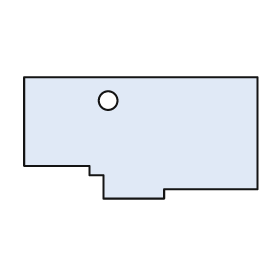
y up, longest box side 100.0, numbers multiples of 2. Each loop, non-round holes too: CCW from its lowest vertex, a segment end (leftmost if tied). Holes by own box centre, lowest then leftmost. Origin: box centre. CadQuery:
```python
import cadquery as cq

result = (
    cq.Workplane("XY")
    .moveTo(-16.0, -26.0)
    .lineTo(10.0, -26.0)
    .lineTo(10.0, -22.0)
    .lineTo(50.0, -22.0)
    .lineTo(50.0, 26.0)
    .lineTo(-50.0, 26.0)
    .lineTo(-50.0, -12.0)
    .lineTo(-22.0, -12.0)
    .lineTo(-22.0, -16.0)
    .lineTo(-16.0, -16.0)
    .close()
    .moveTo(-14.0, 16.0)
    .circle(4.0)
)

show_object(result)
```